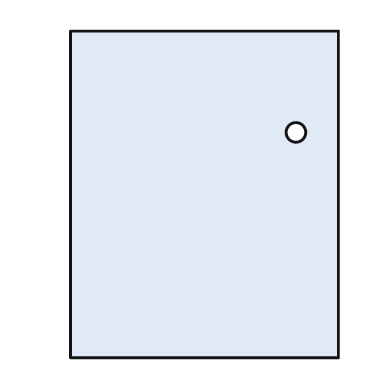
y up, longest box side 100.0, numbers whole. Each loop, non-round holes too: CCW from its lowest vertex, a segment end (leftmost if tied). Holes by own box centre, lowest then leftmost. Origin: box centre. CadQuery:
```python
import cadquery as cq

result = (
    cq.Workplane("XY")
    .moveTo(-41.0, -50.0)
    .lineTo(41.0, -50.0)
    .lineTo(41.0, 50.0)
    .lineTo(-41.0, 50.0)
    .close()
    .moveTo(28.0, 19.0)
    .circle(3.0)
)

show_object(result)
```